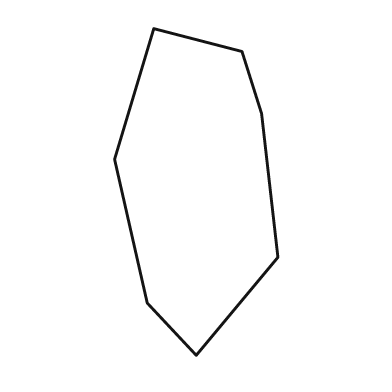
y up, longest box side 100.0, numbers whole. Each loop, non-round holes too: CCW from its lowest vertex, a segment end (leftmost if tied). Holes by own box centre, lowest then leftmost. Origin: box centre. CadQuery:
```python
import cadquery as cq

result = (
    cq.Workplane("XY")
    .moveTo(0.0, -50.0)
    .lineTo(25.0, -20.0)
    .lineTo(20.0, 24.0)
    .lineTo(14.0, 43.0)
    .lineTo(-13.0, 50.0)
    .lineTo(-25.0, 10.0)
    .lineTo(-15.0, -34.0)
    .close()
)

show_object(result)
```